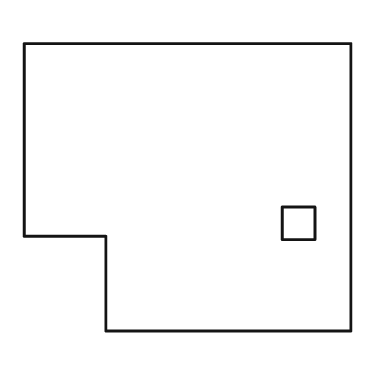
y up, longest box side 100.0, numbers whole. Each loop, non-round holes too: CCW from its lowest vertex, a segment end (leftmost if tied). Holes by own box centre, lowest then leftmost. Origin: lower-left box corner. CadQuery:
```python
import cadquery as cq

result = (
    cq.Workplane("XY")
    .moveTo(25.0, 0.0)
    .lineTo(100.0, 0.0)
    .lineTo(100.0, 88.0)
    .lineTo(0.0, 88.0)
    .lineTo(0.0, 29.0)
    .lineTo(25.0, 29.0)
    .close()
    .moveTo(79.0, 28.0)
    .lineTo(89.0, 28.0)
    .lineTo(89.0, 38.0)
    .lineTo(79.0, 38.0)
    .close()
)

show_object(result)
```